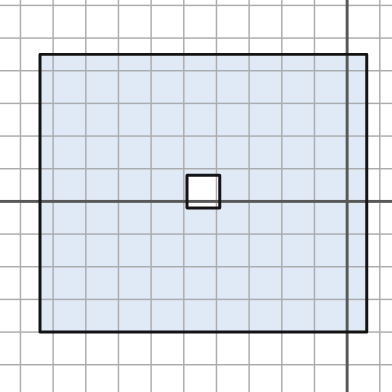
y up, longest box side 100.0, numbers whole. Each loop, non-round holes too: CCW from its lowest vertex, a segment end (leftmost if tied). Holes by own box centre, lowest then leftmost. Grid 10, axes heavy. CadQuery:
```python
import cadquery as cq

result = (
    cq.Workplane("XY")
    .moveTo(-94.0, -40.0)
    .lineTo(6.0, -40.0)
    .lineTo(6.0, 45.0)
    .lineTo(-94.0, 45.0)
    .close()
    .moveTo(-49.0, -2.0)
    .lineTo(-39.0, -2.0)
    .lineTo(-39.0, 8.0)
    .lineTo(-49.0, 8.0)
    .close()
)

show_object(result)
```